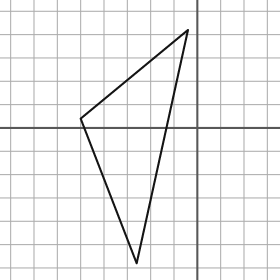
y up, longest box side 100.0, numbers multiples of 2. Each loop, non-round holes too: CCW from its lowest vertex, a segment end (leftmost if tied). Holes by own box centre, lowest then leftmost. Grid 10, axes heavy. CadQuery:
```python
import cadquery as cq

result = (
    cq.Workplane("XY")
    .moveTo(-26.0, -58.0)
    .lineTo(-4.0, 42.0)
    .lineTo(-50.0, 4.0)
    .close()
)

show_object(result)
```